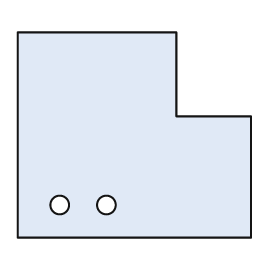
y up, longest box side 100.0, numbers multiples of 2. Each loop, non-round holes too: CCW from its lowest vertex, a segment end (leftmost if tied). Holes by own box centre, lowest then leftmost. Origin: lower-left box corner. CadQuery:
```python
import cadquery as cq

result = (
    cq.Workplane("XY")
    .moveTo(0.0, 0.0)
    .lineTo(100.0, 0.0)
    .lineTo(100.0, 52.0)
    .lineTo(68.0, 52.0)
    .lineTo(68.0, 88.0)
    .lineTo(0.0, 88.0)
    .close()
    .moveTo(18.0, 14.0)
    .circle(4.0)
    .moveTo(38.0, 14.0)
    .circle(4.0)
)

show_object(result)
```